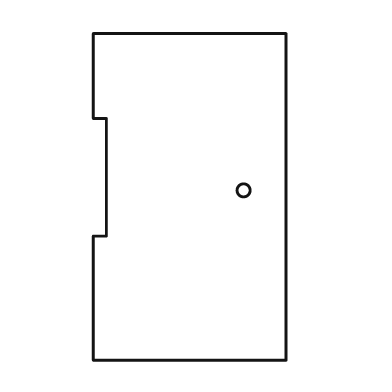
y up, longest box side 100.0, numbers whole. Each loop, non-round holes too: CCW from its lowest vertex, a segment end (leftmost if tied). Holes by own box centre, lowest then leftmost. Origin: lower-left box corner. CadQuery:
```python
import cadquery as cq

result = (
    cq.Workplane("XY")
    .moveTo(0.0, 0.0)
    .lineTo(59.0, 0.0)
    .lineTo(59.0, 100.0)
    .lineTo(0.0, 100.0)
    .lineTo(0.0, 74.0)
    .lineTo(4.0, 74.0)
    .lineTo(4.0, 38.0)
    .lineTo(0.0, 38.0)
    .close()
    .moveTo(46.0, 52.0)
    .circle(2.0)
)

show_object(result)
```